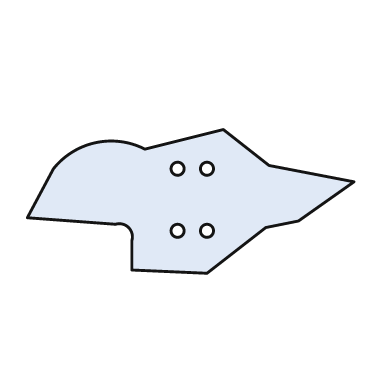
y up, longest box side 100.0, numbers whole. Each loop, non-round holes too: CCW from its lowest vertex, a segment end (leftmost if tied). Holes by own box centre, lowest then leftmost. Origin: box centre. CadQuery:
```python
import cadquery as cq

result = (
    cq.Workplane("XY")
    .moveTo(5.0, -22.0)
    .lineTo(23.0, -8.0)
    .lineTo(33.0, -6.0)
    .lineTo(50.0, 6.0)
    .lineTo(24.0, 11.0)
    .lineTo(10.0, 22.0)
    .lineTo(-14.0, 16.0)
    .threePointArc((-29.0, 18.0), (-42.0, 10.0))
    .lineTo(-50.0, -5.0)
    .lineTo(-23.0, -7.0)
    .threePointArc((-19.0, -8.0), (-18.0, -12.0))
    .lineTo(-18.0, -21.0)
    .close()
    .moveTo(-4.0, -9.0)
    .circle(2.0)
    .moveTo(5.0, -9.0)
    .circle(2.0)
    .moveTo(-4.0, 10.0)
    .circle(2.0)
    .moveTo(5.0, 10.0)
    .circle(2.0)
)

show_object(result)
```